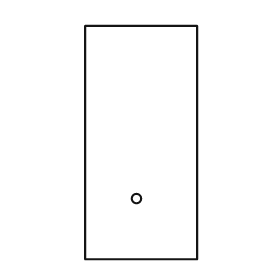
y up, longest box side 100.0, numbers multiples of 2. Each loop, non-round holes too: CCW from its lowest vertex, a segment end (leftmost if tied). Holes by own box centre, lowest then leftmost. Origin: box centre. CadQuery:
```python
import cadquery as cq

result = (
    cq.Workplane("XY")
    .moveTo(-24.0, -50.0)
    .lineTo(24.0, -50.0)
    .lineTo(24.0, 50.0)
    .lineTo(-24.0, 50.0)
    .close()
    .moveTo(-2.0, -24.0)
    .circle(2.0)
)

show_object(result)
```